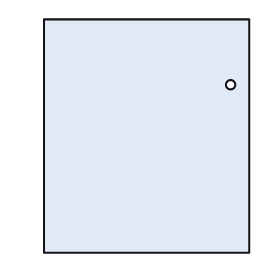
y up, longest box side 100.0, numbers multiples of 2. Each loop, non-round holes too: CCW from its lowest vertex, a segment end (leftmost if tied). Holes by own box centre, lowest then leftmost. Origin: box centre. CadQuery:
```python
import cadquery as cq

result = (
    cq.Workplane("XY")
    .moveTo(-44.0, -50.0)
    .lineTo(44.0, -50.0)
    .lineTo(44.0, 50.0)
    .lineTo(-44.0, 50.0)
    .close()
    .moveTo(36.0, 22.0)
    .circle(2.0)
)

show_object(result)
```